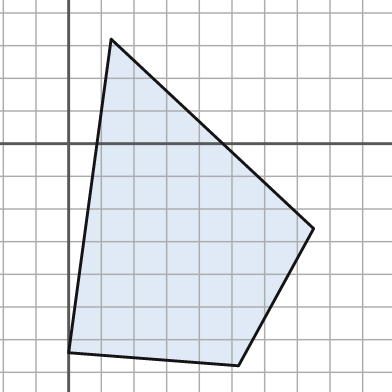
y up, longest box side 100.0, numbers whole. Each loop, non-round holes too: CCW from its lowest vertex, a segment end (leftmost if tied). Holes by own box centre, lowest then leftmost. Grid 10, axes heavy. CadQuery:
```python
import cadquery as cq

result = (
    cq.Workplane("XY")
    .moveTo(52.0, -68.0)
    .lineTo(75.0, -26.0)
    .lineTo(13.0, 32.0)
    .lineTo(0.0, -64.0)
    .close()
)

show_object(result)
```